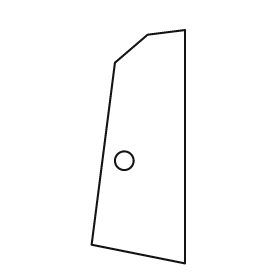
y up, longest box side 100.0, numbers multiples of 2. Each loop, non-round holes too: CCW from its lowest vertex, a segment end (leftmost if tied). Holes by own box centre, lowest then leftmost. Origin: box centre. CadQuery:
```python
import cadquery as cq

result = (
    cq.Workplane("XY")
    .moveTo(20.0, -50.0)
    .lineTo(20.0, 50.0)
    .lineTo(4.0, 48.0)
    .lineTo(-10.0, 36.0)
    .lineTo(-20.0, -42.0)
    .close()
    .moveTo(-6.0, -6.0)
    .circle(4.0)
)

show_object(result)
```